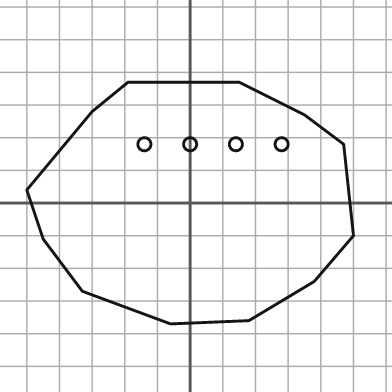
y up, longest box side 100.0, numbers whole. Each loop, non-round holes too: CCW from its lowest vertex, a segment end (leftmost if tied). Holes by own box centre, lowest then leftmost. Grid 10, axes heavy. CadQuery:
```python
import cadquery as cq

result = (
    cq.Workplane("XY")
    .moveTo(-6.0, -37.0)
    .lineTo(18.0, -36.0)
    .lineTo(38.0, -24.0)
    .lineTo(50.0, -10.0)
    .lineTo(47.0, 18.0)
    .lineTo(35.0, 27.0)
    .lineTo(15.0, 37.0)
    .lineTo(-19.0, 37.0)
    .lineTo(-30.0, 28.0)
    .lineTo(-50.0, 4.0)
    .lineTo(-45.0, -11.0)
    .lineTo(-33.0, -27.0)
    .close()
    .moveTo(-14.0, 18.0)
    .circle(2.0)
    .moveTo(0.0, 18.0)
    .circle(2.0)
    .moveTo(14.0, 18.0)
    .circle(2.0)
    .moveTo(28.0, 18.0)
    .circle(2.0)
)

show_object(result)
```